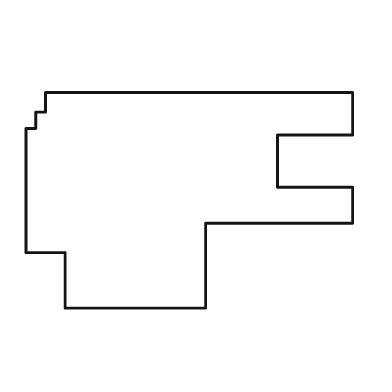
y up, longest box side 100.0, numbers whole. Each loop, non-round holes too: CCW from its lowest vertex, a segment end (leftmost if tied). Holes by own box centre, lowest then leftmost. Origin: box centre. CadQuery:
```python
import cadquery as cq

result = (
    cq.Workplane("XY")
    .moveTo(-38.0, -33.0)
    .lineTo(5.0, -33.0)
    .lineTo(5.0, -7.0)
    .lineTo(50.0, -7.0)
    .lineTo(50.0, 4.0)
    .lineTo(27.0, 4.0)
    .lineTo(27.0, 20.0)
    .lineTo(50.0, 20.0)
    .lineTo(50.0, 33.0)
    .lineTo(-44.0, 33.0)
    .lineTo(-44.0, 27.0)
    .lineTo(-47.0, 27.0)
    .lineTo(-47.0, 22.0)
    .lineTo(-50.0, 22.0)
    .lineTo(-50.0, -16.0)
    .lineTo(-38.0, -16.0)
    .close()
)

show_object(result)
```